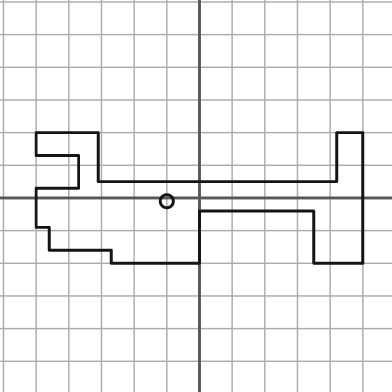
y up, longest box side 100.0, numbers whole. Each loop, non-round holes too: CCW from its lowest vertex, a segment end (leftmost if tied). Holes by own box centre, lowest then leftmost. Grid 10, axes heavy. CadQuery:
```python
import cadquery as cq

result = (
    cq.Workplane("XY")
    .moveTo(-27.0, -20.0)
    .lineTo(0.0, -20.0)
    .lineTo(0.0, -4.0)
    .lineTo(35.0, -4.0)
    .lineTo(35.0, -20.0)
    .lineTo(50.0, -20.0)
    .lineTo(50.0, 20.0)
    .lineTo(42.0, 20.0)
    .lineTo(42.0, 5.0)
    .lineTo(-31.0, 5.0)
    .lineTo(-31.0, 20.0)
    .lineTo(-50.0, 20.0)
    .lineTo(-50.0, 13.0)
    .lineTo(-37.0, 13.0)
    .lineTo(-37.0, 3.0)
    .lineTo(-50.0, 3.0)
    .lineTo(-50.0, -9.0)
    .lineTo(-46.0, -9.0)
    .lineTo(-46.0, -16.0)
    .lineTo(-27.0, -16.0)
    .close()
    .moveTo(-10.0, -1.0)
    .circle(2.0)
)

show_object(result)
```